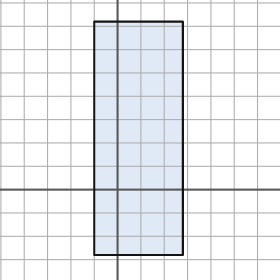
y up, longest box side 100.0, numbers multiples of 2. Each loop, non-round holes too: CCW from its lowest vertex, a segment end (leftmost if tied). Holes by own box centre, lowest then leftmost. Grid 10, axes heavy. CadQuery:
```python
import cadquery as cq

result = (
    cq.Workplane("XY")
    .moveTo(-10.0, -28.0)
    .lineTo(28.0, -28.0)
    .lineTo(28.0, 72.0)
    .lineTo(-10.0, 72.0)
    .close()
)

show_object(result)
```